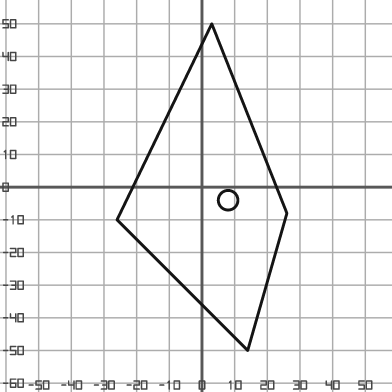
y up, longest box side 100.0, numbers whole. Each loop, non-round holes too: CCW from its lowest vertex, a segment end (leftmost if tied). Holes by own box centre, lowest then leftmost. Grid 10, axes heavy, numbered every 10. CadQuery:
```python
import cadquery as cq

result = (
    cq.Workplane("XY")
    .moveTo(14.0, -50.0)
    .lineTo(26.0, -8.0)
    .lineTo(3.0, 50.0)
    .lineTo(-26.0, -10.0)
    .close()
    .moveTo(8.0, -4.0)
    .circle(3.0)
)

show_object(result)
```